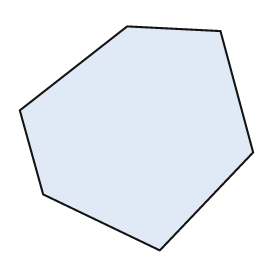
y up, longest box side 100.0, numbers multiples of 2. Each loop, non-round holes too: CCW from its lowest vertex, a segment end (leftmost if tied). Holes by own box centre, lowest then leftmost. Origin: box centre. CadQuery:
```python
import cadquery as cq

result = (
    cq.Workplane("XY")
    .moveTo(10.0, -48.0)
    .lineTo(50.0, -6.0)
    .lineTo(36.0, 46.0)
    .lineTo(-4.0, 48.0)
    .lineTo(-50.0, 12.0)
    .lineTo(-40.0, -24.0)
    .close()
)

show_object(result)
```